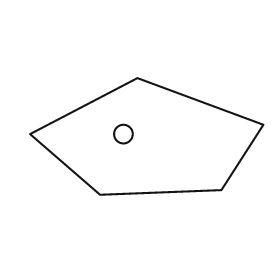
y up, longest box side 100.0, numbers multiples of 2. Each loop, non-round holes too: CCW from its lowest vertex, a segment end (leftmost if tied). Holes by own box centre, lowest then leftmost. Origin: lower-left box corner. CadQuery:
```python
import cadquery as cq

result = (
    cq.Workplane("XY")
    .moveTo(30.0, 0.0)
    .lineTo(82.0, 2.0)
    .lineTo(100.0, 30.0)
    .lineTo(46.0, 50.0)
    .lineTo(0.0, 26.0)
    .close()
    .moveTo(40.0, 26.0)
    .circle(4.0)
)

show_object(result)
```